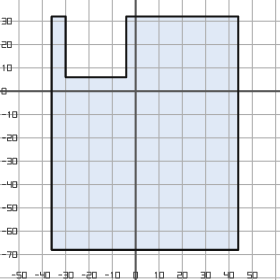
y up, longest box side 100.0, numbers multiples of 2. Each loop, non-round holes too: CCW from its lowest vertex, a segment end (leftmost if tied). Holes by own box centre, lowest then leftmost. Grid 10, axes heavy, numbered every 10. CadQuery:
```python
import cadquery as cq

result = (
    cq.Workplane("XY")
    .moveTo(-36.0, -68.0)
    .lineTo(44.0, -68.0)
    .lineTo(44.0, 32.0)
    .lineTo(-4.0, 32.0)
    .lineTo(-4.0, 6.0)
    .lineTo(-30.0, 6.0)
    .lineTo(-30.0, 32.0)
    .lineTo(-36.0, 32.0)
    .close()
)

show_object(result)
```